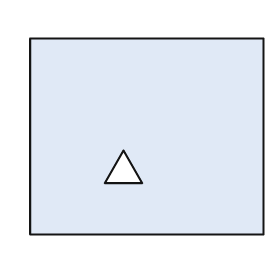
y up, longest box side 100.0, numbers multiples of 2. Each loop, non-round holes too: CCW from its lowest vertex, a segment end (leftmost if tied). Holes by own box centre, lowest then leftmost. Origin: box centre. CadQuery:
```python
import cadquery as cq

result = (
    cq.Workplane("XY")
    .moveTo(-50.0, -42.0)
    .lineTo(50.0, -42.0)
    .lineTo(50.0, 42.0)
    .lineTo(-50.0, 42.0)
    .close()
    .moveTo(-18.0, -20.0)
    .lineTo(-2.0, -20.0)
    .lineTo(-10.0, -6.0)
    .close()
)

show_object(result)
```